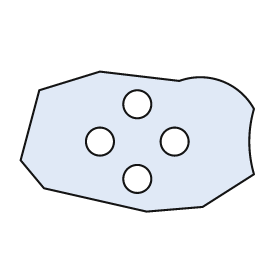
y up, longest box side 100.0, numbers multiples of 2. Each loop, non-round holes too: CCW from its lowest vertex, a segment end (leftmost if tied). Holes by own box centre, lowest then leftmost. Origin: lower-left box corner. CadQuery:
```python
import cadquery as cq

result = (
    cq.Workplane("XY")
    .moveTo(54.0, 0.0)
    .lineTo(78.0, 2.0)
    .lineTo(100.0, 16.0)
    .threePointArc((98.0, 30.0), (100.0, 44.0))
    .threePointArc((86.0, 56.0), (68.0, 56.0))
    .lineTo(34.0, 60.0)
    .lineTo(8.0, 52.0)
    .lineTo(0.0, 22.0)
    .lineTo(10.0, 10.0)
    .close()
    .moveTo(50.0, 14.0)
    .circle(6.0)
    .moveTo(34.0, 30.0)
    .circle(6.0)
    .moveTo(66.0, 30.0)
    .circle(6.0)
    .moveTo(50.0, 46.0)
    .circle(6.0)
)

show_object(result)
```